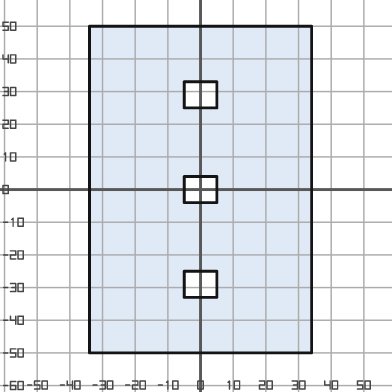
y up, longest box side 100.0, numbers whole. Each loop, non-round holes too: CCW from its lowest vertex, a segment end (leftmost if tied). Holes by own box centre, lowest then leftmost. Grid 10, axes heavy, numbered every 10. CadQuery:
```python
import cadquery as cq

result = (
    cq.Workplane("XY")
    .moveTo(-34.0, -50.0)
    .lineTo(34.0, -50.0)
    .lineTo(34.0, 50.0)
    .lineTo(-34.0, 50.0)
    .close()
    .moveTo(-5.0, -33.0)
    .lineTo(5.0, -33.0)
    .lineTo(5.0, -25.0)
    .lineTo(-5.0, -25.0)
    .close()
    .moveTo(-5.0, -4.0)
    .lineTo(5.0, -4.0)
    .lineTo(5.0, 4.0)
    .lineTo(-5.0, 4.0)
    .close()
    .moveTo(-5.0, 25.0)
    .lineTo(5.0, 25.0)
    .lineTo(5.0, 33.0)
    .lineTo(-5.0, 33.0)
    .close()
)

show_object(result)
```